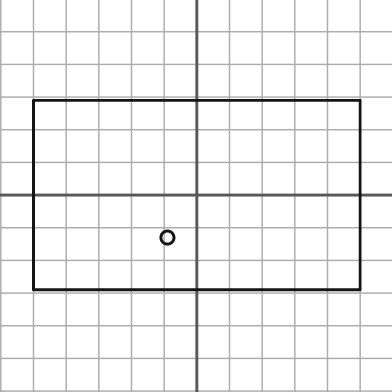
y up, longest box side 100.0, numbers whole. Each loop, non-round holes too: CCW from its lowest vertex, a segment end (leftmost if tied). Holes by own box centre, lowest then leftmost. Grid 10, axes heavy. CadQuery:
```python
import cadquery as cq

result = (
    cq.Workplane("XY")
    .moveTo(-50.0, -29.0)
    .lineTo(50.0, -29.0)
    .lineTo(50.0, 29.0)
    .lineTo(-50.0, 29.0)
    .close()
    .moveTo(-9.0, -13.0)
    .circle(2.0)
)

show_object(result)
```